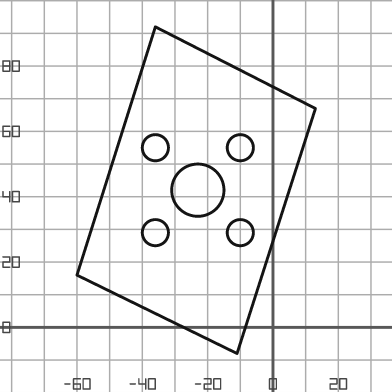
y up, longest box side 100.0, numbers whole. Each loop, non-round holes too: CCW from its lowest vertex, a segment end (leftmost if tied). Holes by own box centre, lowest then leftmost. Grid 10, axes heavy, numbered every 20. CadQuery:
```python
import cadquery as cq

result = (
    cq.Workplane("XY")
    .moveTo(-11.0, -8.0)
    .lineTo(13.0, 67.0)
    .lineTo(-36.0, 92.0)
    .lineTo(-60.0, 16.0)
    .close()
    .moveTo(-36.0, 29.0)
    .circle(4.0)
    .moveTo(-10.0, 29.0)
    .circle(4.0)
    .moveTo(-23.0, 42.0)
    .circle(8.0)
    .moveTo(-36.0, 55.0)
    .circle(4.0)
    .moveTo(-10.0, 55.0)
    .circle(4.0)
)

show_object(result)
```